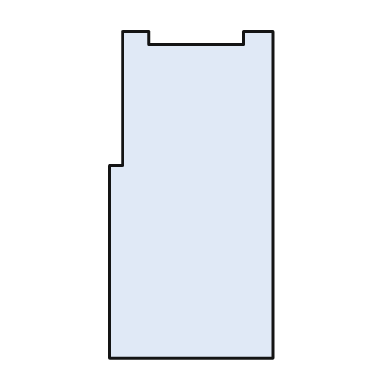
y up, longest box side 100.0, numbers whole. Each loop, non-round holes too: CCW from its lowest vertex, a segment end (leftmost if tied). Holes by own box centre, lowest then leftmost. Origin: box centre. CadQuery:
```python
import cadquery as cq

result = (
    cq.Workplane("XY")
    .moveTo(-25.0, -50.0)
    .lineTo(25.0, -50.0)
    .lineTo(25.0, 50.0)
    .lineTo(16.0, 50.0)
    .lineTo(16.0, 46.0)
    .lineTo(-13.0, 46.0)
    .lineTo(-13.0, 50.0)
    .lineTo(-21.0, 50.0)
    .lineTo(-21.0, 9.0)
    .lineTo(-25.0, 9.0)
    .close()
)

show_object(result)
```